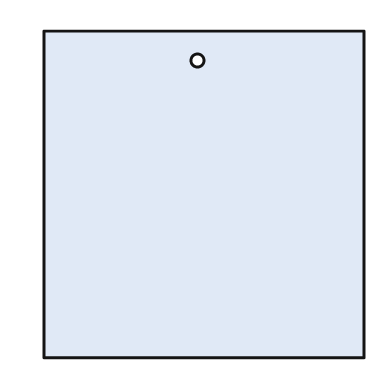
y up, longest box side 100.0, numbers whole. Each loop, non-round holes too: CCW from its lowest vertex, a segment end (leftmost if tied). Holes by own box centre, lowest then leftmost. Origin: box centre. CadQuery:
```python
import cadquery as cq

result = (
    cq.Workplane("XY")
    .moveTo(-49.0, -50.0)
    .lineTo(49.0, -50.0)
    .lineTo(49.0, 50.0)
    .lineTo(-49.0, 50.0)
    .close()
    .moveTo(-2.0, 41.0)
    .circle(2.0)
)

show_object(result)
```